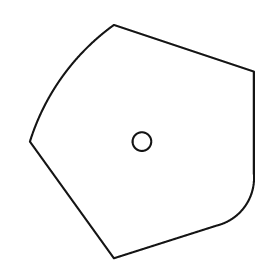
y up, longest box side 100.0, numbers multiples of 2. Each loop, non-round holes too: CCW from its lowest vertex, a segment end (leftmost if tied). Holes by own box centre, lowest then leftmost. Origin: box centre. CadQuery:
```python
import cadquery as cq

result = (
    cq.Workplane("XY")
    .moveTo(-12.0, -50.0)
    .lineTo(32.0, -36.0)
    .threePointArc((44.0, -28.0), (48.0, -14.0))
    .lineTo(48.0, 30.0)
    .lineTo(-12.0, 50.0)
    .threePointArc((-34.0, 28.0), (-48.0, 0.0))
    .close()
    .moveTo(0.0, 0.0)
    .circle(4.0)
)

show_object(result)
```